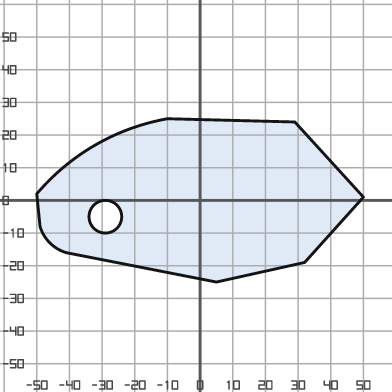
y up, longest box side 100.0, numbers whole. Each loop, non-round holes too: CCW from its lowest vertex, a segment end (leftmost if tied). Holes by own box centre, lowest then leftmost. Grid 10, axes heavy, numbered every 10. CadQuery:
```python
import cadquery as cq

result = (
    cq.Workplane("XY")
    .moveTo(5.0, -25.0)
    .lineTo(32.0, -19.0)
    .lineTo(50.0, 1.0)
    .lineTo(29.0, 24.0)
    .lineTo(-10.0, 25.0)
    .threePointArc((-32.0, 17.0), (-50.0, 2.0))
    .lineTo(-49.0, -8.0)
    .threePointArc((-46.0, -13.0), (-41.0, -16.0))
    .close()
    .moveTo(-29.0, -5.0)
    .circle(5.0)
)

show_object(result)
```